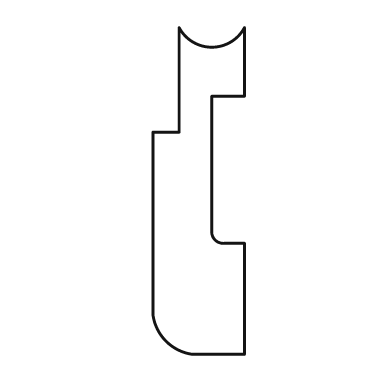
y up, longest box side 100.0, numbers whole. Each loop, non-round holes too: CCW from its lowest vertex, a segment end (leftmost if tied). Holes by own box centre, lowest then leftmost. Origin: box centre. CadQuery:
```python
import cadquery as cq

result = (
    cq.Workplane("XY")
    .moveTo(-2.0, -50.0)
    .lineTo(14.0, -50.0)
    .lineTo(14.0, -16.0)
    .lineTo(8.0, -16.0)
    .threePointArc((5.0, -15.0), (4.0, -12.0))
    .lineTo(4.0, 29.0)
    .lineTo(14.0, 29.0)
    .lineTo(14.0, 50.0)
    .threePointArc((4.0, 44.0), (-6.0, 50.0))
    .lineTo(-6.0, 18.0)
    .lineTo(-14.0, 18.0)
    .lineTo(-14.0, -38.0)
    .threePointArc((-10.0, -46.0), (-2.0, -50.0))
    .close()
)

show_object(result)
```